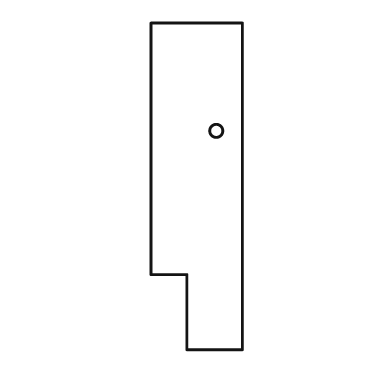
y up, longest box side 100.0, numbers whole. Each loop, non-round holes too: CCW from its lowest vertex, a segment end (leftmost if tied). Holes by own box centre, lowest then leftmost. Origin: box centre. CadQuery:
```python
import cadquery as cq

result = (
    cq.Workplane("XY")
    .moveTo(-3.0, -50.0)
    .lineTo(14.0, -50.0)
    .lineTo(14.0, 50.0)
    .lineTo(-14.0, 50.0)
    .lineTo(-14.0, -27.0)
    .lineTo(-3.0, -27.0)
    .close()
    .moveTo(6.0, 17.0)
    .circle(2.0)
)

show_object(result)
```